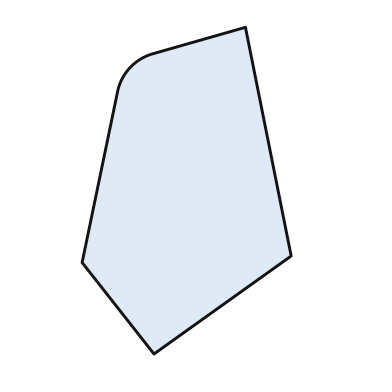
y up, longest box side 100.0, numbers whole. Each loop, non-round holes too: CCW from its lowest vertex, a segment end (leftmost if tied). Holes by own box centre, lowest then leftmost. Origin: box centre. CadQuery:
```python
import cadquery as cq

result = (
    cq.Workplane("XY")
    .moveTo(-10.0, -50.0)
    .lineTo(32.0, -20.0)
    .lineTo(18.0, 50.0)
    .lineTo(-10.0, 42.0)
    .threePointArc((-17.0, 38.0), (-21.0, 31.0))
    .lineTo(-32.0, -22.0)
    .close()
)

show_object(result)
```